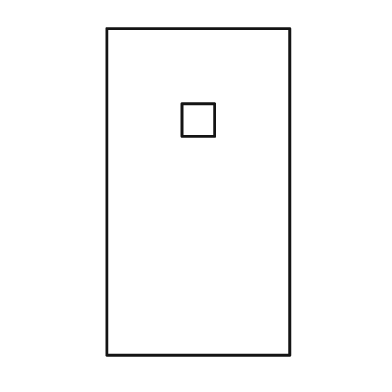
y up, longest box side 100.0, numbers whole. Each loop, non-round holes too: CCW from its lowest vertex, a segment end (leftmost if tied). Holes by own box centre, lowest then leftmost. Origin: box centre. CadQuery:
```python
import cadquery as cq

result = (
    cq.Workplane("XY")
    .moveTo(-28.0, -50.0)
    .lineTo(28.0, -50.0)
    .lineTo(28.0, 50.0)
    .lineTo(-28.0, 50.0)
    .close()
    .moveTo(-5.0, 17.0)
    .lineTo(5.0, 17.0)
    .lineTo(5.0, 27.0)
    .lineTo(-5.0, 27.0)
    .close()
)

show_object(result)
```